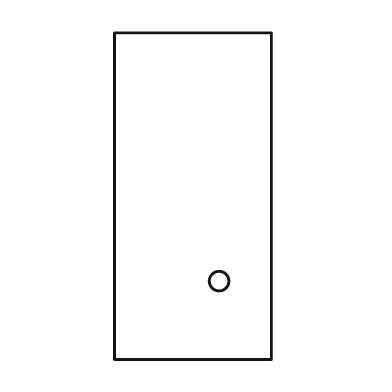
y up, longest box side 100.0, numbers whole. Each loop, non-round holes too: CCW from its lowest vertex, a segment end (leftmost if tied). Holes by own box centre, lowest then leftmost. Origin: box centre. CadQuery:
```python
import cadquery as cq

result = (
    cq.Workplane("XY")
    .moveTo(-24.0, -50.0)
    .lineTo(24.0, -50.0)
    .lineTo(24.0, 50.0)
    .lineTo(-24.0, 50.0)
    .close()
    .moveTo(8.0, -26.0)
    .circle(3.0)
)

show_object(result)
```